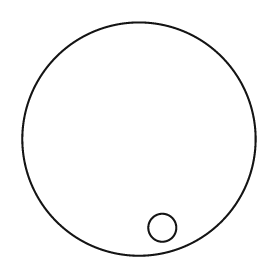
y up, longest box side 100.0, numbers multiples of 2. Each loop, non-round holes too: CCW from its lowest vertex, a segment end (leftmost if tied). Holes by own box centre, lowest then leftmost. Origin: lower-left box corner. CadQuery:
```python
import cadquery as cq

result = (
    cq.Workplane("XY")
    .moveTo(50.0, 50.0)
    .circle(50.0)
    .moveTo(60.0, 12.0)
    .circle(6.0)
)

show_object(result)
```